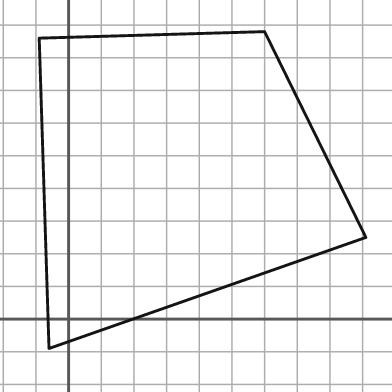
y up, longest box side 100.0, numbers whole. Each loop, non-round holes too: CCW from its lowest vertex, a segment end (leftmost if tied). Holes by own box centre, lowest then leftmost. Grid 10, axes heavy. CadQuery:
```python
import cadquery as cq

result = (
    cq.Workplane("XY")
    .moveTo(-6.0, -9.0)
    .lineTo(91.0, 25.0)
    .lineTo(60.0, 88.0)
    .lineTo(-9.0, 86.0)
    .close()
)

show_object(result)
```